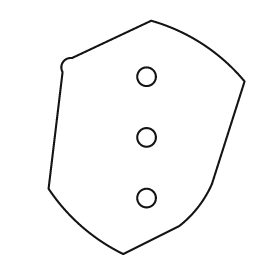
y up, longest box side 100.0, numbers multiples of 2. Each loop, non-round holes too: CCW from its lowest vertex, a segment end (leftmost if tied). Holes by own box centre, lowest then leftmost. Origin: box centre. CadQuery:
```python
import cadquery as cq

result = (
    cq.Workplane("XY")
    .moveTo(-10.0, -50.0)
    .lineTo(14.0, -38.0)
    .threePointArc((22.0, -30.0), (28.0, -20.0))
    .lineTo(42.0, 24.0)
    .threePointArc((24.0, 40.0), (2.0, 50.0))
    .lineTo(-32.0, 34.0)
    .threePointArc((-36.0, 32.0), (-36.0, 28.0))
    .lineTo(-42.0, -22.0)
    .threePointArc((-28.0, -38.0), (-10.0, -50.0))
    .close()
    .moveTo(0.0, -26.0)
    .circle(4.0)
    .moveTo(0.0, 0.0)
    .circle(4.0)
    .moveTo(0.0, 26.0)
    .circle(4.0)
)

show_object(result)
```